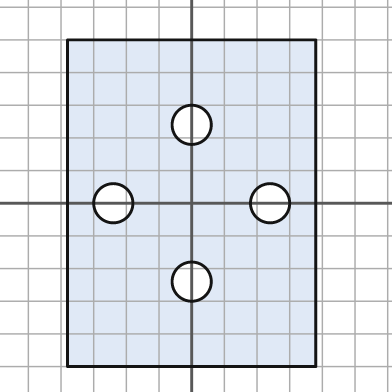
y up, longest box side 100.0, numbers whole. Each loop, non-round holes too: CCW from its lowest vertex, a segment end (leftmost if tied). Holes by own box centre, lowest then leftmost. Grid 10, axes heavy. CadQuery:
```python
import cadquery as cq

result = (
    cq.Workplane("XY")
    .moveTo(-38.0, -50.0)
    .lineTo(38.0, -50.0)
    .lineTo(38.0, 50.0)
    .lineTo(-38.0, 50.0)
    .close()
    .moveTo(0.0, -24.0)
    .circle(6.0)
    .moveTo(-24.0, 0.0)
    .circle(6.0)
    .moveTo(24.0, 0.0)
    .circle(6.0)
    .moveTo(0.0, 24.0)
    .circle(6.0)
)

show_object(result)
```